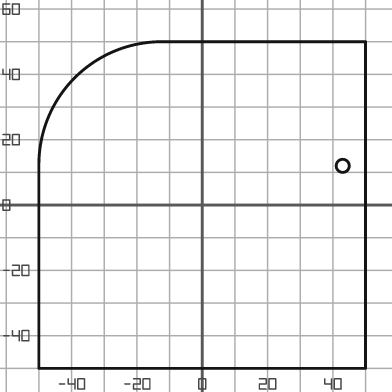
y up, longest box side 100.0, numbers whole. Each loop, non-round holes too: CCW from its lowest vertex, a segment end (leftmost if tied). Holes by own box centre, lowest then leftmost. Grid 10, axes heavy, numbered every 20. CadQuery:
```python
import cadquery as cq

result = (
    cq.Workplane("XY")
    .moveTo(-50.0, -50.0)
    .lineTo(50.0, -50.0)
    .lineTo(50.0, 50.0)
    .lineTo(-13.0, 50.0)
    .threePointArc((-39.0, 39.0), (-50.0, 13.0))
    .close()
    .moveTo(43.0, 12.0)
    .circle(2.0)
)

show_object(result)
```